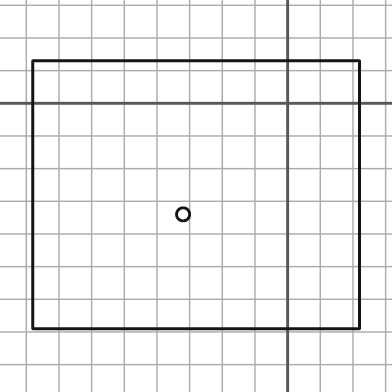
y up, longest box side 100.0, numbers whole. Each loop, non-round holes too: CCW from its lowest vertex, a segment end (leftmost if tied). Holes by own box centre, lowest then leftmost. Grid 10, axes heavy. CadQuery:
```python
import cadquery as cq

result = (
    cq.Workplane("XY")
    .moveTo(-78.0, -69.0)
    .lineTo(22.0, -69.0)
    .lineTo(22.0, 13.0)
    .lineTo(-78.0, 13.0)
    .close()
    .moveTo(-32.0, -34.0)
    .circle(2.0)
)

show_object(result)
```